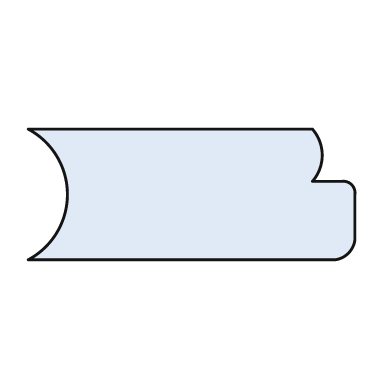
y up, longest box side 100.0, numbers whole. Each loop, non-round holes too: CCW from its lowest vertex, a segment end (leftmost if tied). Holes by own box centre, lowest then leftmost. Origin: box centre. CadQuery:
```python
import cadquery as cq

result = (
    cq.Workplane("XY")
    .moveTo(-50.0, -20.0)
    .lineTo(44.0, -20.0)
    .threePointArc((48.0, -18.0), (50.0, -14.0))
    .lineTo(50.0, 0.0)
    .threePointArc((49.0, 3.0), (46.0, 4.0))
    .lineTo(37.0, 4.0)
    .threePointArc((40.0, 12.0), (37.0, 20.0))
    .lineTo(-50.0, 20.0)
    .threePointArc((-38.0, 0.0), (-50.0, -20.0))
    .close()
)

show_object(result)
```